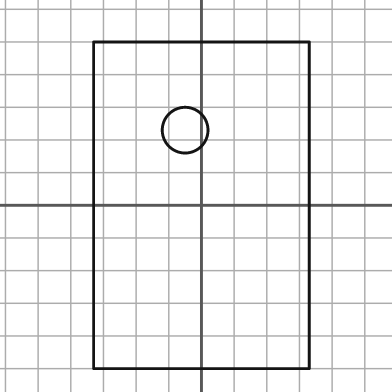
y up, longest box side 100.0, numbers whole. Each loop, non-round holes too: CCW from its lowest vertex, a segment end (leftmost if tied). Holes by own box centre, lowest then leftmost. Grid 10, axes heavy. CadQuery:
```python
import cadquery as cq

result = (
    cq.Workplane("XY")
    .moveTo(-33.0, -50.0)
    .lineTo(33.0, -50.0)
    .lineTo(33.0, 50.0)
    .lineTo(-33.0, 50.0)
    .close()
    .moveTo(-5.0, 23.0)
    .circle(7.0)
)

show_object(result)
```